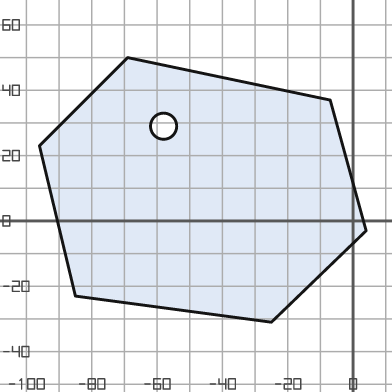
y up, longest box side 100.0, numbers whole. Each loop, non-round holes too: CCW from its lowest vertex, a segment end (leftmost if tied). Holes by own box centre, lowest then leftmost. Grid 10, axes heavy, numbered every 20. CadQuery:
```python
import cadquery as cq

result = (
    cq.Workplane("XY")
    .moveTo(-25.0, -31.0)
    .lineTo(4.0, -3.0)
    .lineTo(-7.0, 37.0)
    .lineTo(-69.0, 50.0)
    .lineTo(-96.0, 23.0)
    .lineTo(-85.0, -23.0)
    .close()
    .moveTo(-58.0, 29.0)
    .circle(4.0)
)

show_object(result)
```